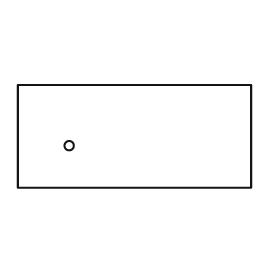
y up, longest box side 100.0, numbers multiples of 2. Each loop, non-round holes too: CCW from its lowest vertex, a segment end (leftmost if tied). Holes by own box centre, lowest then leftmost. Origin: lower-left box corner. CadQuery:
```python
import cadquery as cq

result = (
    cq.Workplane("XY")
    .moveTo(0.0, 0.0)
    .lineTo(100.0, 0.0)
    .lineTo(100.0, 44.0)
    .lineTo(0.0, 44.0)
    .close()
    .moveTo(22.0, 18.0)
    .circle(2.0)
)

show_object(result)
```